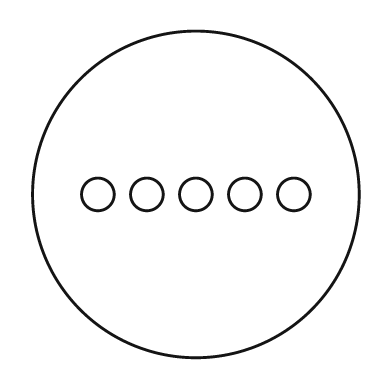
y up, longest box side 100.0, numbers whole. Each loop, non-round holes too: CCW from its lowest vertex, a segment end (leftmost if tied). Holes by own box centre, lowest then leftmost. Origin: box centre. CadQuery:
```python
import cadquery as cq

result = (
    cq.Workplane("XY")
    .moveTo(0.0, 0.0)
    .circle(50.0)
    .moveTo(-30.0, 0.0)
    .circle(5.0)
    .moveTo(-15.0, 0.0)
    .circle(5.0)
    .moveTo(0.0, 0.0)
    .circle(5.0)
    .moveTo(15.0, 0.0)
    .circle(5.0)
    .moveTo(30.0, 0.0)
    .circle(5.0)
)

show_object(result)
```